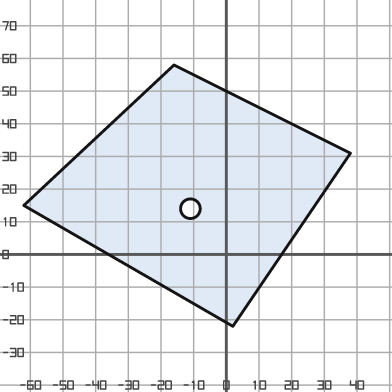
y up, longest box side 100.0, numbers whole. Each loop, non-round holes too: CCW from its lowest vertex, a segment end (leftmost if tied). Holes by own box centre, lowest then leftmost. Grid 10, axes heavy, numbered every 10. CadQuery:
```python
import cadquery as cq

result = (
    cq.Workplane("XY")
    .moveTo(2.0, -22.0)
    .lineTo(38.0, 31.0)
    .lineTo(-16.0, 58.0)
    .lineTo(-62.0, 15.0)
    .close()
    .moveTo(-11.0, 14.0)
    .circle(3.0)
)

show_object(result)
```